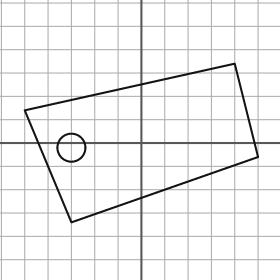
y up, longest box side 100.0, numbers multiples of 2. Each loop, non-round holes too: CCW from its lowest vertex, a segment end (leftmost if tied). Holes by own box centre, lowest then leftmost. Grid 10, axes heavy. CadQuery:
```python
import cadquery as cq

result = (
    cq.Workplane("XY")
    .moveTo(-30.0, -34.0)
    .lineTo(50.0, -6.0)
    .lineTo(40.0, 34.0)
    .lineTo(-50.0, 14.0)
    .close()
    .moveTo(-30.0, -2.0)
    .circle(6.0)
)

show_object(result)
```